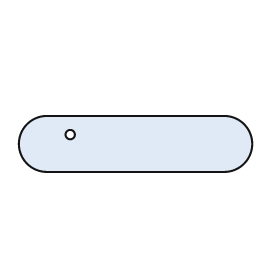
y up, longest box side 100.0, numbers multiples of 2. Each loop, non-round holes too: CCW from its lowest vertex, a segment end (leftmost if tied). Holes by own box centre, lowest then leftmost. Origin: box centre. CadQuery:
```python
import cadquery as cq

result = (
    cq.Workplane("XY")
    .moveTo(-38.0, -12.0)
    .lineTo(38.0, -12.0)
    .threePointArc((50.0, 0.0), (38.0, 12.0))
    .lineTo(-38.0, 12.0)
    .threePointArc((-50.0, 0.0), (-38.0, -12.0))
    .close()
    .moveTo(-28.0, 4.0)
    .circle(2.0)
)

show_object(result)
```